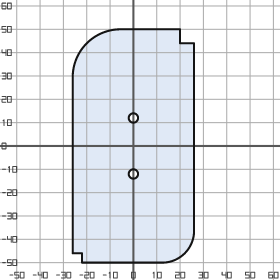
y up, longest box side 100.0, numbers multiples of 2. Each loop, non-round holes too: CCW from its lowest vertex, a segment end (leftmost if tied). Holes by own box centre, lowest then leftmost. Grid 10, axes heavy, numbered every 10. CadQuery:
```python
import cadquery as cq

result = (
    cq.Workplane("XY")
    .moveTo(-22.0, -50.0)
    .lineTo(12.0, -50.0)
    .threePointArc((22.0, -46.0), (26.0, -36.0))
    .lineTo(26.0, 44.0)
    .lineTo(20.0, 44.0)
    .lineTo(20.0, 50.0)
    .lineTo(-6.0, 50.0)
    .threePointArc((-20.0, 44.0), (-26.0, 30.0))
    .lineTo(-26.0, -46.0)
    .lineTo(-22.0, -46.0)
    .close()
    .moveTo(0.0, -12.0)
    .circle(2.0)
    .moveTo(0.0, 12.0)
    .circle(2.0)
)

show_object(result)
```